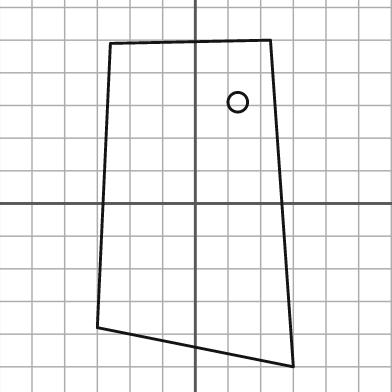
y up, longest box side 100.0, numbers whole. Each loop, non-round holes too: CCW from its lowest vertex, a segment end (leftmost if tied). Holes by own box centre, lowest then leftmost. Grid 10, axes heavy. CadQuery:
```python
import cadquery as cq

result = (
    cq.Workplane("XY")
    .moveTo(30.0, -50.0)
    .lineTo(23.0, 50.0)
    .lineTo(-26.0, 49.0)
    .lineTo(-30.0, -38.0)
    .close()
    .moveTo(13.0, 31.0)
    .circle(3.0)
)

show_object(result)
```